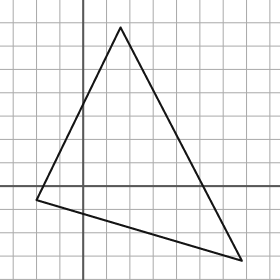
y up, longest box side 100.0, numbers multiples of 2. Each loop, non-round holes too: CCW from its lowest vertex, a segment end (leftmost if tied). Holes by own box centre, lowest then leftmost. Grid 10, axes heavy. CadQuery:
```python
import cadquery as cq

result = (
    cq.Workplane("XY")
    .moveTo(68.0, -32.0)
    .lineTo(16.0, 68.0)
    .lineTo(-20.0, -6.0)
    .close()
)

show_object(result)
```